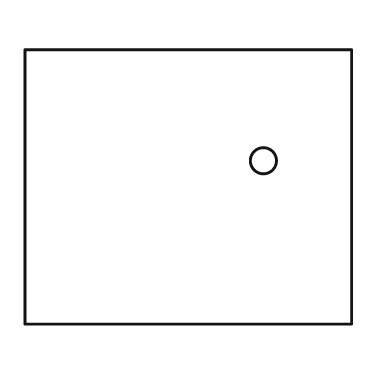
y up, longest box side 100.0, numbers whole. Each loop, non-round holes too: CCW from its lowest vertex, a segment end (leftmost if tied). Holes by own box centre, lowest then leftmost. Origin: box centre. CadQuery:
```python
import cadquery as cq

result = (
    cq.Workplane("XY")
    .moveTo(-50.0, -42.0)
    .lineTo(50.0, -42.0)
    .lineTo(50.0, 42.0)
    .lineTo(-50.0, 42.0)
    .close()
    .moveTo(23.0, 8.0)
    .circle(4.0)
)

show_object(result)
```